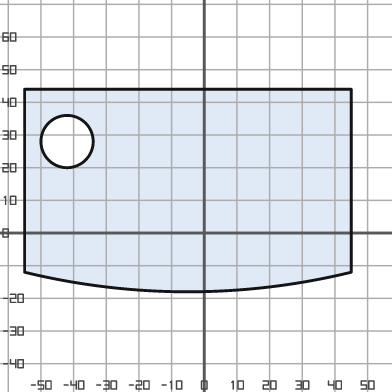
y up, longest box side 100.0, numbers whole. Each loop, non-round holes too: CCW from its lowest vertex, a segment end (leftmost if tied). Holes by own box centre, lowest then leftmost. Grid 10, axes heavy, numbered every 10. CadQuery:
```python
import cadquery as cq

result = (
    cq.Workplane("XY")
    .moveTo(-55.0, -12.0)
    .threePointArc((-5.0, -18.0), (45.0, -12.0))
    .lineTo(45.0, 44.0)
    .lineTo(-55.0, 44.0)
    .close()
    .moveTo(-42.0, 28.0)
    .circle(8.0)
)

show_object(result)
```